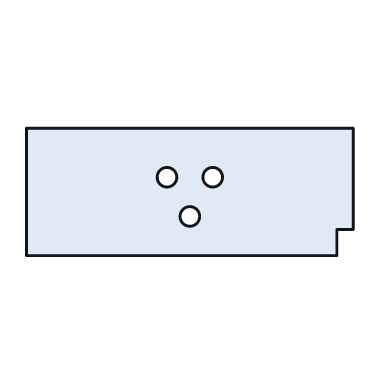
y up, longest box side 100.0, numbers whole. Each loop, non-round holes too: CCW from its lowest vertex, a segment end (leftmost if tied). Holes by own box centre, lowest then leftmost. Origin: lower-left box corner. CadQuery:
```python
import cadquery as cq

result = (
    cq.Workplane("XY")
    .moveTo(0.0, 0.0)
    .lineTo(95.0, 0.0)
    .lineTo(95.0, 8.0)
    .lineTo(100.0, 8.0)
    .lineTo(100.0, 39.0)
    .lineTo(0.0, 39.0)
    .close()
    .moveTo(50.0, 12.0)
    .circle(3.0)
    .moveTo(43.0, 24.0)
    .circle(3.0)
    .moveTo(57.0, 24.0)
    .circle(3.0)
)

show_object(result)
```